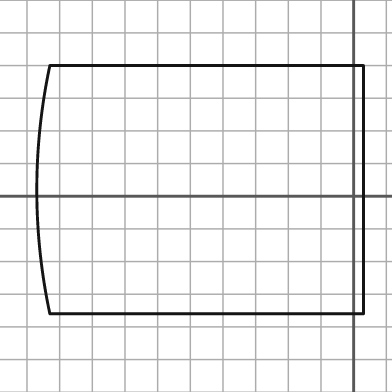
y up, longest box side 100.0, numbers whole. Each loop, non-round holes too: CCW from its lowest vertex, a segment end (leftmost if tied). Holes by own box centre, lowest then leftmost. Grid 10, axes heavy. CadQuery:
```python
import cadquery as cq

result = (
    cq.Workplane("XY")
    .moveTo(-93.0, -36.0)
    .lineTo(3.0, -36.0)
    .lineTo(3.0, 40.0)
    .lineTo(-93.0, 40.0)
    .threePointArc((-97.0, 2.0), (-93.0, -36.0))
    .close()
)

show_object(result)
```